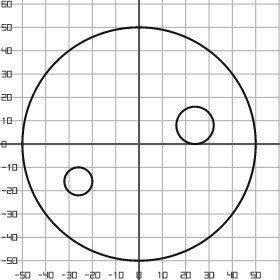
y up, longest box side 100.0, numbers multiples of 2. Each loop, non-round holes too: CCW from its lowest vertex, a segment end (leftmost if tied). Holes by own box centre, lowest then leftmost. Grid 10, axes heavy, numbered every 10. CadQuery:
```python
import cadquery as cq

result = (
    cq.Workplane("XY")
    .moveTo(0.0, 0.0)
    .circle(50.0)
    .moveTo(-26.0, -16.0)
    .circle(6.0)
    .moveTo(24.0, 8.0)
    .circle(8.0)
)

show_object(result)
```